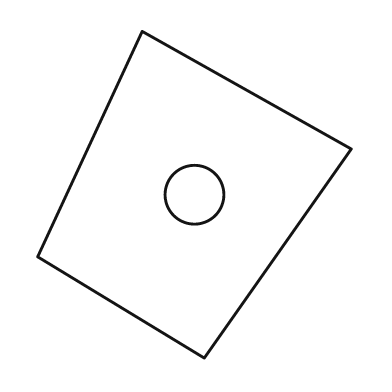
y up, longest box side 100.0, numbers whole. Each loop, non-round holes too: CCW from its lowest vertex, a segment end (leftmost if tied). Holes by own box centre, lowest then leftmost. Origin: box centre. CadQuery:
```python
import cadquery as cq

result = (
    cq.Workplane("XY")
    .moveTo(3.0, -50.0)
    .lineTo(48.0, 14.0)
    .lineTo(-16.0, 50.0)
    .lineTo(-48.0, -19.0)
    .close()
    .moveTo(0.0, 0.0)
    .circle(9.0)
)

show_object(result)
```